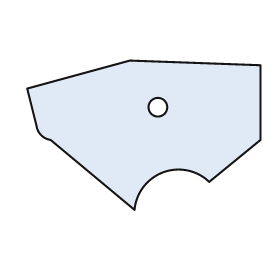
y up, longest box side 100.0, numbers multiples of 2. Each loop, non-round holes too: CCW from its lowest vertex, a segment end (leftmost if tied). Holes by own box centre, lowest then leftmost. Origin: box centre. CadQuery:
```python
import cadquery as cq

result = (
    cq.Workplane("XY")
    .moveTo(-4.0, -32.0)
    .threePointArc((8.0, -16.0), (28.0, -20.0))
    .lineTo(50.0, -2.0)
    .lineTo(50.0, 30.0)
    .lineTo(-6.0, 32.0)
    .lineTo(-50.0, 20.0)
    .lineTo(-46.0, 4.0)
    .threePointArc((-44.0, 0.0), (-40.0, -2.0))
    .close()
    .moveTo(6.0, 12.0)
    .circle(4.0)
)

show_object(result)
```